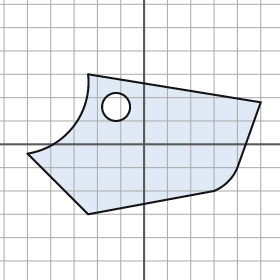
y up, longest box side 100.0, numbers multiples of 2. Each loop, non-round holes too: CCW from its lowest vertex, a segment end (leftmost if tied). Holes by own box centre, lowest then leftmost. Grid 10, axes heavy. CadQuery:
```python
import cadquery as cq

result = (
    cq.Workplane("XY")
    .moveTo(-24.0, -30.0)
    .lineTo(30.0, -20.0)
    .threePointArc((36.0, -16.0), (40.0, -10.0))
    .lineTo(50.0, 18.0)
    .lineTo(-24.0, 30.0)
    .threePointArc((-30.0, 8.0), (-50.0, -4.0))
    .close()
    .moveTo(-12.0, 16.0)
    .circle(6.0)
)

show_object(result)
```